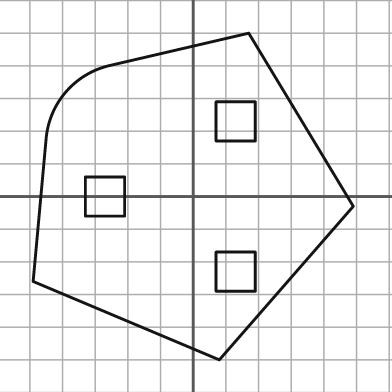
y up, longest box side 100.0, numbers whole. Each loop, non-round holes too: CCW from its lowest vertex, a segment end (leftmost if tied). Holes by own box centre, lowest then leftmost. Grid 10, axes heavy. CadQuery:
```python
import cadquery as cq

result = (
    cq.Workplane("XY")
    .moveTo(8.0, -50.0)
    .lineTo(49.0, -3.0)
    .lineTo(17.0, 50.0)
    .lineTo(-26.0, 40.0)
    .threePointArc((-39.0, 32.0), (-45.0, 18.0))
    .lineTo(-49.0, -26.0)
    .close()
    .moveTo(7.0, -29.0)
    .lineTo(19.0, -29.0)
    .lineTo(19.0, -17.0)
    .lineTo(7.0, -17.0)
    .close()
    .moveTo(-33.0, -6.0)
    .lineTo(-21.0, -6.0)
    .lineTo(-21.0, 6.0)
    .lineTo(-33.0, 6.0)
    .close()
    .moveTo(7.0, 17.0)
    .lineTo(19.0, 17.0)
    .lineTo(19.0, 29.0)
    .lineTo(7.0, 29.0)
    .close()
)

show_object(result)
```